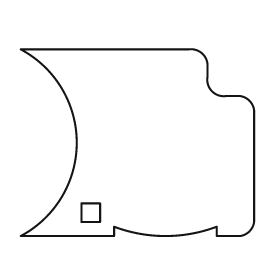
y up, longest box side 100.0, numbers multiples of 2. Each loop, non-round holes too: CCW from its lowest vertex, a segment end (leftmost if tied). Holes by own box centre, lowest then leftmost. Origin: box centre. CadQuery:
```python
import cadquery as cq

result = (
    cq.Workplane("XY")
    .moveTo(-50.0, -40.0)
    .lineTo(-10.0, -40.0)
    .lineTo(-10.0, -36.0)
    .threePointArc((12.0, -40.0), (34.0, -36.0))
    .lineTo(34.0, -40.0)
    .lineTo(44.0, -40.0)
    .threePointArc((48.0, -38.0), (50.0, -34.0))
    .lineTo(50.0, 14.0)
    .threePointArc((48.0, 18.0), (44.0, 20.0))
    .lineTo(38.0, 20.0)
    .threePointArc((32.0, 22.0), (30.0, 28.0))
    .lineTo(30.0, 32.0)
    .threePointArc((28.0, 38.0), (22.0, 40.0))
    .lineTo(-50.0, 40.0)
    .threePointArc((-26.0, 0.0), (-50.0, -40.0))
    .close()
    .moveTo(-24.0, -34.0)
    .lineTo(-16.0, -34.0)
    .lineTo(-16.0, -26.0)
    .lineTo(-24.0, -26.0)
    .close()
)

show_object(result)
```